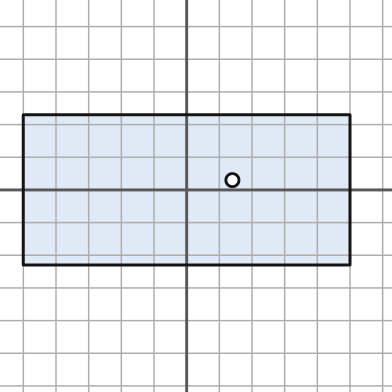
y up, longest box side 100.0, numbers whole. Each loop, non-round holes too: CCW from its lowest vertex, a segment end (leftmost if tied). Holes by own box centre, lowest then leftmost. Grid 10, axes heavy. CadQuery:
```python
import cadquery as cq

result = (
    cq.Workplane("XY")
    .moveTo(-50.0, -23.0)
    .lineTo(50.0, -23.0)
    .lineTo(50.0, 23.0)
    .lineTo(-50.0, 23.0)
    .close()
    .moveTo(14.0, 3.0)
    .circle(2.0)
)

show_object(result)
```